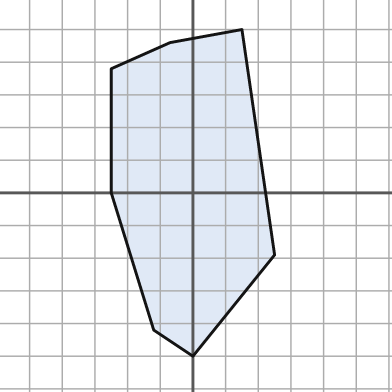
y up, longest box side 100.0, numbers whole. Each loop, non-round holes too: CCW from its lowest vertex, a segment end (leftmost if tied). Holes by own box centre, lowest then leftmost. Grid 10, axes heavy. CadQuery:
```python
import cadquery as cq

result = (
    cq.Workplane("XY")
    .moveTo(0.0, -50.0)
    .lineTo(25.0, -19.0)
    .lineTo(15.0, 50.0)
    .lineTo(-7.0, 46.0)
    .lineTo(-25.0, 38.0)
    .lineTo(-25.0, 0.0)
    .lineTo(-12.0, -42.0)
    .close()
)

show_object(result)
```